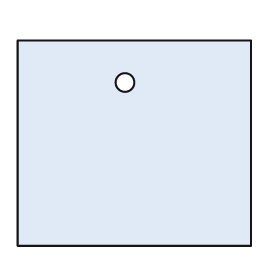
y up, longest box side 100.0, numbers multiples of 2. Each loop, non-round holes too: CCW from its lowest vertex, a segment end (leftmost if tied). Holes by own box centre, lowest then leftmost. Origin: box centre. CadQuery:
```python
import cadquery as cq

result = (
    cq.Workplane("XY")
    .moveTo(-50.0, -44.0)
    .lineTo(50.0, -44.0)
    .lineTo(50.0, 44.0)
    .lineTo(-50.0, 44.0)
    .close()
    .moveTo(-4.0, 26.0)
    .circle(4.0)
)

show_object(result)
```